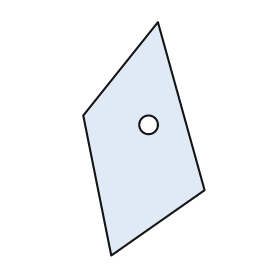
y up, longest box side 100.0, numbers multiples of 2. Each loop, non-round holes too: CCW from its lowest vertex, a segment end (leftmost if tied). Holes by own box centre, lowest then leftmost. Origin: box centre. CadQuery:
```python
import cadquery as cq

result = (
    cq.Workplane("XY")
    .moveTo(-14.0, -50.0)
    .lineTo(26.0, -22.0)
    .lineTo(6.0, 50.0)
    .lineTo(-26.0, 10.0)
    .close()
    .moveTo(2.0, 6.0)
    .circle(4.0)
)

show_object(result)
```